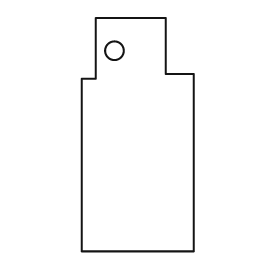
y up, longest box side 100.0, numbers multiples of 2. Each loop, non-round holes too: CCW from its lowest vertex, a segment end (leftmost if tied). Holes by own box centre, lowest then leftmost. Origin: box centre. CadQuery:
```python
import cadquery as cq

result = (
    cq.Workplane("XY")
    .moveTo(-24.0, -50.0)
    .lineTo(24.0, -50.0)
    .lineTo(24.0, 26.0)
    .lineTo(12.0, 26.0)
    .lineTo(12.0, 50.0)
    .lineTo(-18.0, 50.0)
    .lineTo(-18.0, 24.0)
    .lineTo(-24.0, 24.0)
    .close()
    .moveTo(-10.0, 36.0)
    .circle(4.0)
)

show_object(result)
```